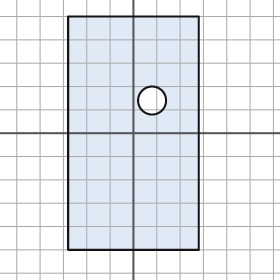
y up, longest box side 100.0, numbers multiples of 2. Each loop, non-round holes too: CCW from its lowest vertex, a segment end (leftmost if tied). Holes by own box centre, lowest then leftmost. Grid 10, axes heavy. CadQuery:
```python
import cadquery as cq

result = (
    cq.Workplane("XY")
    .moveTo(-28.0, -50.0)
    .lineTo(28.0, -50.0)
    .lineTo(28.0, 50.0)
    .lineTo(-28.0, 50.0)
    .close()
    .moveTo(8.0, 14.0)
    .circle(6.0)
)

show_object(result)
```